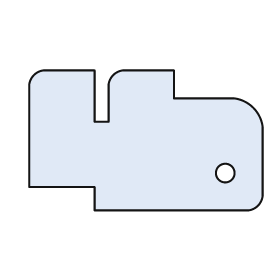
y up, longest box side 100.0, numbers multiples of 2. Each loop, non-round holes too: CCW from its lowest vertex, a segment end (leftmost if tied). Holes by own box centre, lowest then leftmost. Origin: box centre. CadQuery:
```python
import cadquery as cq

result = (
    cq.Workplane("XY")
    .moveTo(-22.0, -30.0)
    .lineTo(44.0, -30.0)
    .threePointArc((48.0, -28.0), (50.0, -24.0))
    .lineTo(50.0, 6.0)
    .threePointArc((46.0, 14.0), (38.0, 18.0))
    .lineTo(12.0, 18.0)
    .lineTo(12.0, 30.0)
    .lineTo(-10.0, 30.0)
    .threePointArc((-14.0, 28.0), (-16.0, 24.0))
    .lineTo(-16.0, 8.0)
    .lineTo(-22.0, 8.0)
    .lineTo(-22.0, 30.0)
    .lineTo(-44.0, 30.0)
    .threePointArc((-48.0, 28.0), (-50.0, 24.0))
    .lineTo(-50.0, -20.0)
    .lineTo(-22.0, -20.0)
    .close()
    .moveTo(34.0, -14.0)
    .circle(4.0)
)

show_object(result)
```